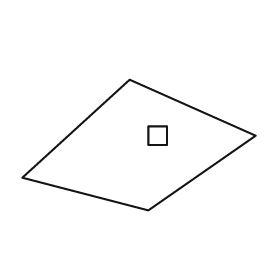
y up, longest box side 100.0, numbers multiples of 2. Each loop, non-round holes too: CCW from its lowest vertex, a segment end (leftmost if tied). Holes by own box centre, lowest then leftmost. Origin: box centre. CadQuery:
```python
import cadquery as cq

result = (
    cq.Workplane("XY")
    .moveTo(4.0, -28.0)
    .lineTo(50.0, 4.0)
    .lineTo(-4.0, 28.0)
    .lineTo(-50.0, -14.0)
    .close()
    .moveTo(4.0, 0.0)
    .lineTo(12.0, 0.0)
    .lineTo(12.0, 8.0)
    .lineTo(4.0, 8.0)
    .close()
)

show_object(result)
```